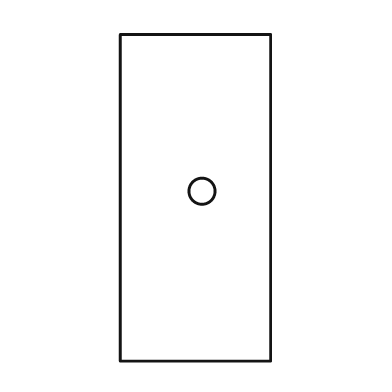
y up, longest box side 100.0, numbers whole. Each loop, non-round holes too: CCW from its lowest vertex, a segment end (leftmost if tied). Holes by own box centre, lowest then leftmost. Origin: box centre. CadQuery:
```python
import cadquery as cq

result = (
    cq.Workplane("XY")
    .moveTo(-23.0, -50.0)
    .lineTo(23.0, -50.0)
    .lineTo(23.0, 50.0)
    .lineTo(-23.0, 50.0)
    .close()
    .moveTo(2.0, 2.0)
    .circle(4.0)
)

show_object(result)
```